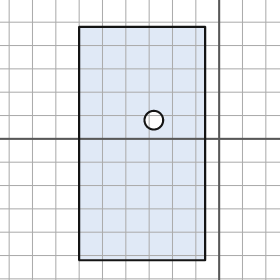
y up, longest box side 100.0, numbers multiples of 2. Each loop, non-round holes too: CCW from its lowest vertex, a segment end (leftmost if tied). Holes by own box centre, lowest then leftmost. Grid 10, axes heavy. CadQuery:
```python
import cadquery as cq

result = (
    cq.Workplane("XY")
    .moveTo(-60.0, -52.0)
    .lineTo(-6.0, -52.0)
    .lineTo(-6.0, 48.0)
    .lineTo(-60.0, 48.0)
    .close()
    .moveTo(-28.0, 8.0)
    .circle(4.0)
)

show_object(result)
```